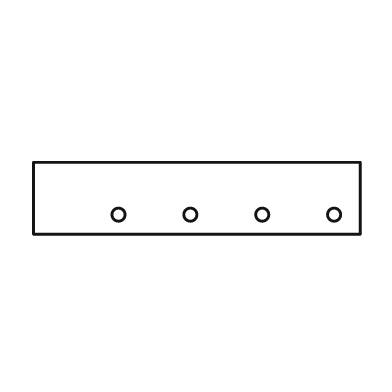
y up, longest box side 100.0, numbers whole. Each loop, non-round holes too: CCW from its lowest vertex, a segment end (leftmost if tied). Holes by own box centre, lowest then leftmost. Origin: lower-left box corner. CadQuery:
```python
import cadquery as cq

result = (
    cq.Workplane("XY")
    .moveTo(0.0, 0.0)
    .lineTo(100.0, 0.0)
    .lineTo(100.0, 22.0)
    .lineTo(0.0, 22.0)
    .close()
    .moveTo(26.0, 6.0)
    .circle(2.0)
    .moveTo(48.0, 6.0)
    .circle(2.0)
    .moveTo(70.0, 6.0)
    .circle(2.0)
    .moveTo(92.0, 6.0)
    .circle(2.0)
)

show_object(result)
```